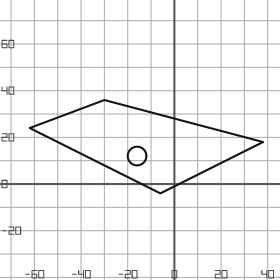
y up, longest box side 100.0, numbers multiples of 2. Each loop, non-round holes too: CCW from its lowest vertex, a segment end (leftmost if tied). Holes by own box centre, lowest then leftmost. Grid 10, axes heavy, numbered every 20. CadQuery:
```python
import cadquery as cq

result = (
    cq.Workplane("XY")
    .moveTo(-6.0, -4.0)
    .lineTo(38.0, 18.0)
    .lineTo(-30.0, 36.0)
    .lineTo(-62.0, 24.0)
    .close()
    .moveTo(-16.0, 12.0)
    .circle(4.0)
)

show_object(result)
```